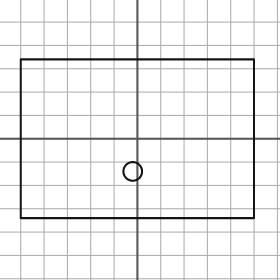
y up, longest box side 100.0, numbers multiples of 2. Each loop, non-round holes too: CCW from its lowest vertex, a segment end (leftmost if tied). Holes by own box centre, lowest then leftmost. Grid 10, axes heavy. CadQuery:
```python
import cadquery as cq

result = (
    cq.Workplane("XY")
    .moveTo(-50.0, -34.0)
    .lineTo(50.0, -34.0)
    .lineTo(50.0, 34.0)
    .lineTo(-50.0, 34.0)
    .close()
    .moveTo(-2.0, -14.0)
    .circle(4.0)
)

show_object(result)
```